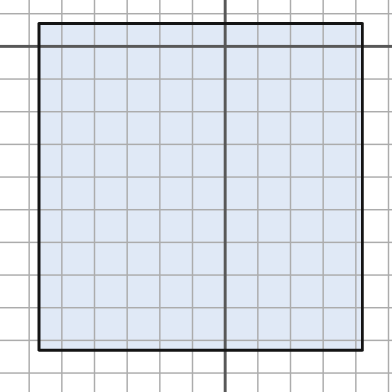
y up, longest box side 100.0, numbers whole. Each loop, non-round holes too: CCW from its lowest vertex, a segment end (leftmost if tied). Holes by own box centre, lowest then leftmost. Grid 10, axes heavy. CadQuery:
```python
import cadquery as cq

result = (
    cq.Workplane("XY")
    .moveTo(-57.0, -93.0)
    .lineTo(42.0, -93.0)
    .lineTo(42.0, 7.0)
    .lineTo(-57.0, 7.0)
    .close()
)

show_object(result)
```